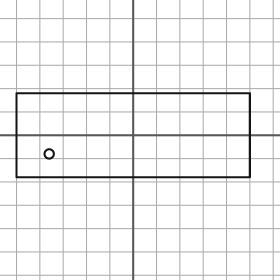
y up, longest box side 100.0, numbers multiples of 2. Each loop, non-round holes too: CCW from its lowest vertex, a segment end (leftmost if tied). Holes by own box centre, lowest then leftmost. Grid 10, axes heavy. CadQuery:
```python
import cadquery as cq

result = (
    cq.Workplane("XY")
    .moveTo(-50.0, -18.0)
    .lineTo(50.0, -18.0)
    .lineTo(50.0, 18.0)
    .lineTo(-50.0, 18.0)
    .close()
    .moveTo(-36.0, -8.0)
    .circle(2.0)
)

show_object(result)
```